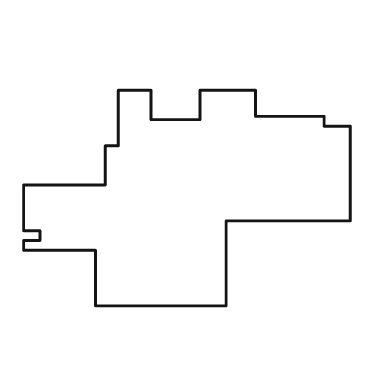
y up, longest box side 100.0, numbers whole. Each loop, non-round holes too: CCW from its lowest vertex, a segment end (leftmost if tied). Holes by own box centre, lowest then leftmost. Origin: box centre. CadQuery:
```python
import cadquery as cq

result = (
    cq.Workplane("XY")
    .moveTo(-28.0, -33.0)
    .lineTo(12.0, -33.0)
    .lineTo(12.0, -7.0)
    .lineTo(50.0, -7.0)
    .lineTo(50.0, 22.0)
    .lineTo(42.0, 22.0)
    .lineTo(42.0, 25.0)
    .lineTo(21.0, 25.0)
    .lineTo(21.0, 33.0)
    .lineTo(4.0, 33.0)
    .lineTo(4.0, 24.0)
    .lineTo(-11.0, 24.0)
    .lineTo(-11.0, 33.0)
    .lineTo(-21.0, 33.0)
    .lineTo(-21.0, 16.0)
    .lineTo(-25.0, 16.0)
    .lineTo(-25.0, 4.0)
    .lineTo(-50.0, 4.0)
    .lineTo(-50.0, -10.0)
    .lineTo(-45.0, -10.0)
    .lineTo(-45.0, -13.0)
    .lineTo(-50.0, -13.0)
    .lineTo(-50.0, -16.0)
    .lineTo(-28.0, -16.0)
    .close()
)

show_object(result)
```